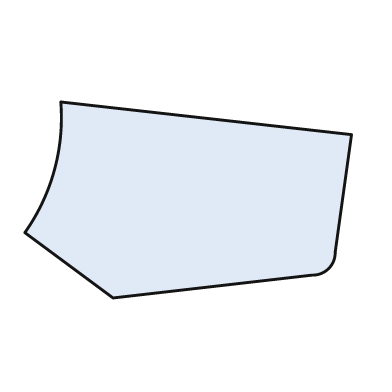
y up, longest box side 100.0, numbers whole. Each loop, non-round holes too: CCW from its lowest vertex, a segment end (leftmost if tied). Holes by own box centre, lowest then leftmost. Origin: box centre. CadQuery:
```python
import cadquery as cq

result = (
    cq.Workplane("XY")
    .moveTo(-23.0, -30.0)
    .lineTo(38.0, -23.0)
    .threePointArc((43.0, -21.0), (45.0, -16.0))
    .lineTo(50.0, 20.0)
    .lineTo(-39.0, 30.0)
    .threePointArc((-41.0, 9.0), (-50.0, -10.0))
    .close()
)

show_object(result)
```